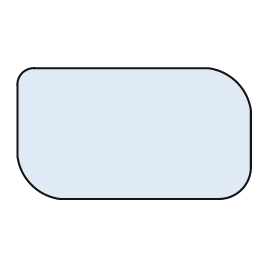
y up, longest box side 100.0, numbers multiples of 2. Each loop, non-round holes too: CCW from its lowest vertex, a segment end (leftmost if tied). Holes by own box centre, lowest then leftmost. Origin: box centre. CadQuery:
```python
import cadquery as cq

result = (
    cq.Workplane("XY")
    .moveTo(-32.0, -28.0)
    .lineTo(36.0, -28.0)
    .threePointArc((46.0, -24.0), (50.0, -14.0))
    .lineTo(50.0, 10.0)
    .threePointArc((44.0, 22.0), (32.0, 28.0))
    .lineTo(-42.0, 28.0)
    .threePointArc((-48.0, 26.0), (-50.0, 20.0))
    .lineTo(-50.0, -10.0)
    .threePointArc((-44.0, -22.0), (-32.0, -28.0))
    .close()
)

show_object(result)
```